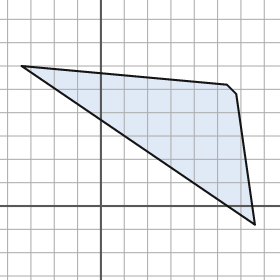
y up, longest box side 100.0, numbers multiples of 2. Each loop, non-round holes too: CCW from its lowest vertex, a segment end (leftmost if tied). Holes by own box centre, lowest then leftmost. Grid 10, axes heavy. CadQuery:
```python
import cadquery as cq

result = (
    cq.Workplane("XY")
    .moveTo(66.0, -8.0)
    .lineTo(58.0, 48.0)
    .lineTo(54.0, 52.0)
    .lineTo(-34.0, 60.0)
    .close()
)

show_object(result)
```